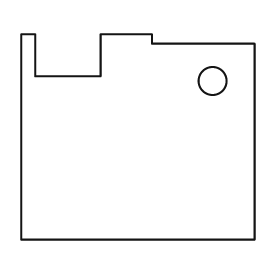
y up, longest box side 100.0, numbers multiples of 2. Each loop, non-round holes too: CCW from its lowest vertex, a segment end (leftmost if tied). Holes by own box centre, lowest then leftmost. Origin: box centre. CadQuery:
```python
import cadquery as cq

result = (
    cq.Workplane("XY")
    .moveTo(-50.0, -44.0)
    .lineTo(50.0, -44.0)
    .lineTo(50.0, 40.0)
    .lineTo(6.0, 40.0)
    .lineTo(6.0, 44.0)
    .lineTo(-16.0, 44.0)
    .lineTo(-16.0, 26.0)
    .lineTo(-44.0, 26.0)
    .lineTo(-44.0, 44.0)
    .lineTo(-50.0, 44.0)
    .close()
    .moveTo(32.0, 24.0)
    .circle(6.0)
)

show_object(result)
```